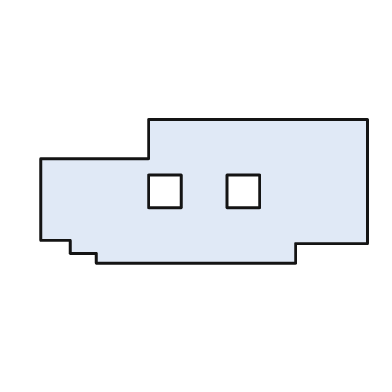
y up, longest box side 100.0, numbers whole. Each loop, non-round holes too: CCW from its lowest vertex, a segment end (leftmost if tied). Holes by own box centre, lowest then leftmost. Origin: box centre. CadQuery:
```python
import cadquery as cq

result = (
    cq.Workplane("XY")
    .moveTo(-33.0, -22.0)
    .lineTo(28.0, -22.0)
    .lineTo(28.0, -16.0)
    .lineTo(50.0, -16.0)
    .lineTo(50.0, 22.0)
    .lineTo(-17.0, 22.0)
    .lineTo(-17.0, 10.0)
    .lineTo(-50.0, 10.0)
    .lineTo(-50.0, -15.0)
    .lineTo(-41.0, -15.0)
    .lineTo(-41.0, -19.0)
    .lineTo(-33.0, -19.0)
    .close()
    .moveTo(-17.0, -5.0)
    .lineTo(-7.0, -5.0)
    .lineTo(-7.0, 5.0)
    .lineTo(-17.0, 5.0)
    .close()
    .moveTo(7.0, -5.0)
    .lineTo(17.0, -5.0)
    .lineTo(17.0, 5.0)
    .lineTo(7.0, 5.0)
    .close()
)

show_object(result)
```